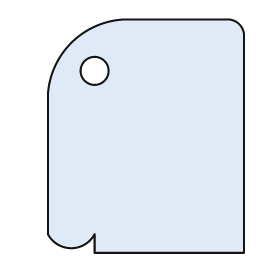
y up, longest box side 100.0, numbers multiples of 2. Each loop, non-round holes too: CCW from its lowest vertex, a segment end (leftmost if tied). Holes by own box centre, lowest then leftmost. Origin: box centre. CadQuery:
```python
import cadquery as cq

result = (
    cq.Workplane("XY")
    .moveTo(-22.0, -50.0)
    .lineTo(42.0, -50.0)
    .lineTo(42.0, 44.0)
    .threePointArc((40.0, 48.0), (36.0, 50.0))
    .lineTo(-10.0, 50.0)
    .threePointArc((-32.0, 40.0), (-42.0, 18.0))
    .lineTo(-42.0, -42.0)
    .threePointArc((-32.0, -48.0), (-22.0, -42.0))
    .close()
    .moveTo(-22.0, 28.0)
    .circle(6.0)
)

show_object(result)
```